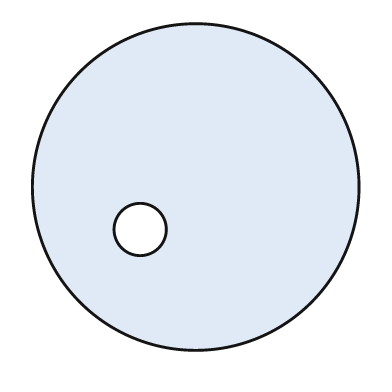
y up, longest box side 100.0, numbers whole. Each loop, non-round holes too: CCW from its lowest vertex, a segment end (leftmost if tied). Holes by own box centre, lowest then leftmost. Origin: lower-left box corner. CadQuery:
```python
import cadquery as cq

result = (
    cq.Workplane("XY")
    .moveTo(50.0, 50.0)
    .circle(50.0)
    .moveTo(33.0, 37.0)
    .circle(8.0)
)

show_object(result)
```